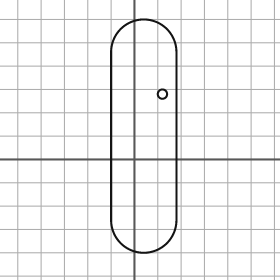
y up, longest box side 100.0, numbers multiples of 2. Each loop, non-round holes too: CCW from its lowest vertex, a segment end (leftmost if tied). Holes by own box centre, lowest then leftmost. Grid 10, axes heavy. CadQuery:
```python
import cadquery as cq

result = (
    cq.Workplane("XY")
    .moveTo(-10.0, -26.0)
    .threePointArc((4.0, -40.0), (18.0, -26.0))
    .lineTo(18.0, 46.0)
    .threePointArc((4.0, 60.0), (-10.0, 46.0))
    .close()
    .moveTo(12.0, 28.0)
    .circle(2.0)
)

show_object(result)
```